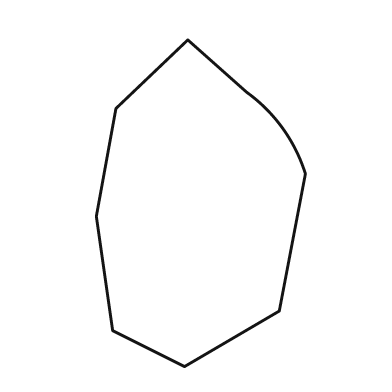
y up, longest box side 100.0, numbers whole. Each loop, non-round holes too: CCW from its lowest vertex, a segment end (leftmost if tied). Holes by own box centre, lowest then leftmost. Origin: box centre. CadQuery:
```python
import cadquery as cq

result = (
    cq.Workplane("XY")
    .moveTo(-5.0, -50.0)
    .lineTo(24.0, -33.0)
    .lineTo(32.0, 9.0)
    .threePointArc((25.0, 23.0), (14.0, 34.0))
    .lineTo(-4.0, 50.0)
    .lineTo(-26.0, 29.0)
    .lineTo(-32.0, -4.0)
    .lineTo(-27.0, -39.0)
    .close()
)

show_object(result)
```